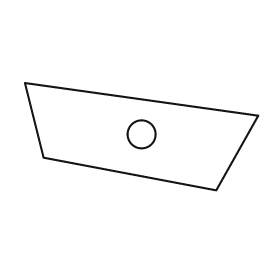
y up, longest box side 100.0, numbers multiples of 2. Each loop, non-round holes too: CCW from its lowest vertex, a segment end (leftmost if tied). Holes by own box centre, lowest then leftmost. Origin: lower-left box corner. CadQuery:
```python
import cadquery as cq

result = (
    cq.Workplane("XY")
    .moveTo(82.0, 0.0)
    .lineTo(100.0, 32.0)
    .lineTo(0.0, 46.0)
    .lineTo(8.0, 14.0)
    .close()
    .moveTo(50.0, 24.0)
    .circle(6.0)
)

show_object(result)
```